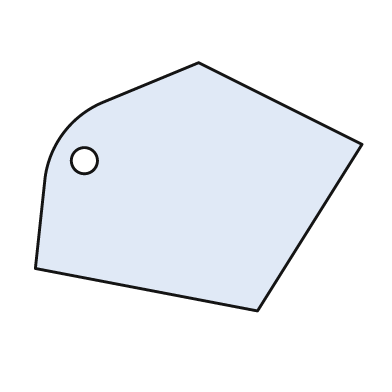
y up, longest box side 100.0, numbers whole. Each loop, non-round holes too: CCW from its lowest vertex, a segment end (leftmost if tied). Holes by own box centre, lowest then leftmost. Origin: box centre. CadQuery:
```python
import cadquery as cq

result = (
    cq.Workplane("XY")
    .moveTo(18.0, -38.0)
    .lineTo(50.0, 13.0)
    .lineTo(0.0, 38.0)
    .lineTo(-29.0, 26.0)
    .threePointArc((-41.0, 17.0), (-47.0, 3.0))
    .lineTo(-50.0, -25.0)
    .close()
    .moveTo(-35.0, 8.0)
    .circle(4.0)
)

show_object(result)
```